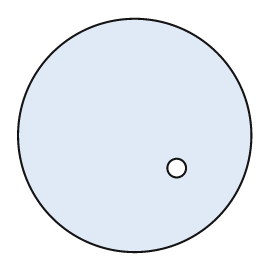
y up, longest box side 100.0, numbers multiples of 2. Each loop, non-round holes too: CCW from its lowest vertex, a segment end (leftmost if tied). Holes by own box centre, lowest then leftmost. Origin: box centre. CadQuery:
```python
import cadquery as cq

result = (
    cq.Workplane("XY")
    .moveTo(0.0, 0.0)
    .circle(50.0)
    .moveTo(18.0, -14.0)
    .circle(4.0)
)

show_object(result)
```